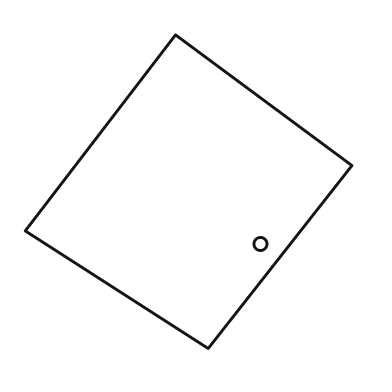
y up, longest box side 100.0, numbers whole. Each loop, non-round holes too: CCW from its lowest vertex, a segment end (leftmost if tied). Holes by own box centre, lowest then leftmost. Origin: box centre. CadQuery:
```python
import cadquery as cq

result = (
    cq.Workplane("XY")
    .moveTo(6.0, -48.0)
    .lineTo(50.0, 8.0)
    .lineTo(-4.0, 48.0)
    .lineTo(-50.0, -12.0)
    .close()
    .moveTo(22.0, -16.0)
    .circle(2.0)
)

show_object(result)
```